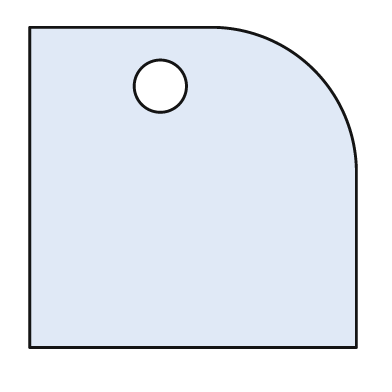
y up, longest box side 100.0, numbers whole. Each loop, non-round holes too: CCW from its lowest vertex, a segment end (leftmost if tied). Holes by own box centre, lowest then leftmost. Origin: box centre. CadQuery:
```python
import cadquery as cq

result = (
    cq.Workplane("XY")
    .moveTo(-50.0, -49.0)
    .lineTo(50.0, -49.0)
    .lineTo(50.0, 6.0)
    .threePointArc((37.0, 36.0), (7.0, 49.0))
    .lineTo(-50.0, 49.0)
    .close()
    .moveTo(-10.0, 31.0)
    .circle(8.0)
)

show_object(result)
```